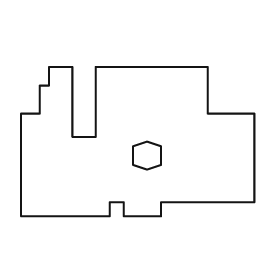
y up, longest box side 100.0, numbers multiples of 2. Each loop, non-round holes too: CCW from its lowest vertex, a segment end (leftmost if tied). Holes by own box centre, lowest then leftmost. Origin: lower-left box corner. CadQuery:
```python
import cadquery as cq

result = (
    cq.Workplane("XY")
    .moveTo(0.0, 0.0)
    .lineTo(38.0, 0.0)
    .lineTo(38.0, 6.0)
    .lineTo(44.0, 6.0)
    .lineTo(44.0, 0.0)
    .lineTo(60.0, 0.0)
    .lineTo(60.0, 6.0)
    .lineTo(100.0, 6.0)
    .lineTo(100.0, 44.0)
    .lineTo(80.0, 44.0)
    .lineTo(80.0, 64.0)
    .lineTo(32.0, 64.0)
    .lineTo(32.0, 34.0)
    .lineTo(22.0, 34.0)
    .lineTo(22.0, 64.0)
    .lineTo(12.0, 64.0)
    .lineTo(12.0, 56.0)
    .lineTo(8.0, 56.0)
    .lineTo(8.0, 44.0)
    .lineTo(0.0, 44.0)
    .close()
    .moveTo(54.0, 20.0)
    .lineTo(60.0, 22.0)
    .lineTo(60.0, 30.0)
    .lineTo(54.0, 32.0)
    .lineTo(48.0, 30.0)
    .lineTo(48.0, 22.0)
    .close()
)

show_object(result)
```